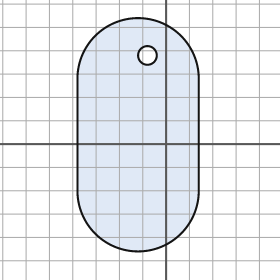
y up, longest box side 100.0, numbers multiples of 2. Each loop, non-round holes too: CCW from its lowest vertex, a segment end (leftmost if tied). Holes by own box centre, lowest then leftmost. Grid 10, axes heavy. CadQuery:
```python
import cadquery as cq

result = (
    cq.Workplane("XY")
    .moveTo(-38.0, -20.0)
    .threePointArc((-12.0, -46.0), (14.0, -20.0))
    .lineTo(14.0, 28.0)
    .threePointArc((-12.0, 54.0), (-38.0, 28.0))
    .close()
    .moveTo(-8.0, 38.0)
    .circle(4.0)
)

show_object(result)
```